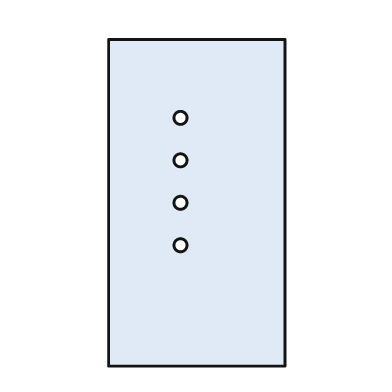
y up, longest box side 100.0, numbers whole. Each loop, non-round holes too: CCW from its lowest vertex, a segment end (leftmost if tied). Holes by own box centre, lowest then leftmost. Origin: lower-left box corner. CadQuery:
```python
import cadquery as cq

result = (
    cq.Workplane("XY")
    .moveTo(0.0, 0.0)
    .lineTo(54.0, 0.0)
    .lineTo(54.0, 100.0)
    .lineTo(0.0, 100.0)
    .close()
    .moveTo(22.0, 37.0)
    .circle(2.0)
    .moveTo(22.0, 50.0)
    .circle(2.0)
    .moveTo(22.0, 63.0)
    .circle(2.0)
    .moveTo(22.0, 76.0)
    .circle(2.0)
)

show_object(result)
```